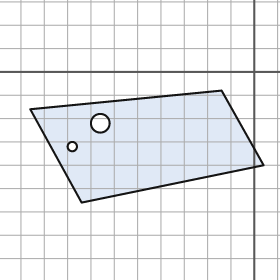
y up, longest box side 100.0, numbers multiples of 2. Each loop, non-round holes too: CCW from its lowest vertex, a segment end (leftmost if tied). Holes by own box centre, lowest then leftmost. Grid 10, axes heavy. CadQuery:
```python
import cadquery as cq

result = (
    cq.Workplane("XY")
    .moveTo(-74.0, -56.0)
    .lineTo(4.0, -40.0)
    .lineTo(-14.0, -8.0)
    .lineTo(-96.0, -16.0)
    .close()
    .moveTo(-78.0, -32.0)
    .circle(2.0)
    .moveTo(-66.0, -22.0)
    .circle(4.0)
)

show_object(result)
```